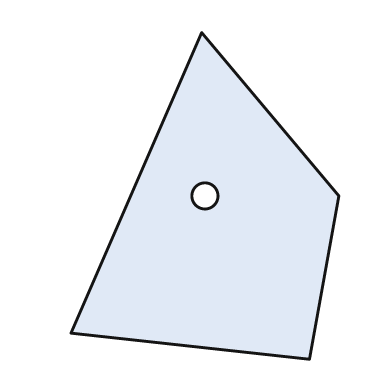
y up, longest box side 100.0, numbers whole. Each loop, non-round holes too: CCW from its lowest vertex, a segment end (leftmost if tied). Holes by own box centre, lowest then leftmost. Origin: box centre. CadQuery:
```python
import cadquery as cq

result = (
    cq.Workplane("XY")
    .moveTo(32.0, -50.0)
    .lineTo(41.0, 0.0)
    .lineTo(-1.0, 50.0)
    .lineTo(-41.0, -42.0)
    .close()
    .moveTo(0.0, 0.0)
    .circle(4.0)
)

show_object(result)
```